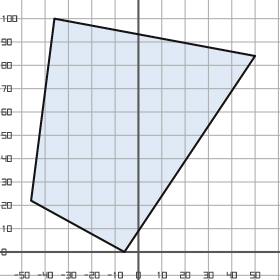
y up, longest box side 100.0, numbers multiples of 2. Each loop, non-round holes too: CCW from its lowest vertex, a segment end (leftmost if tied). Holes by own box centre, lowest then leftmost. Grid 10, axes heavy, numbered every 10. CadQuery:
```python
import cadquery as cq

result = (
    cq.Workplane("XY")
    .moveTo(-6.0, 0.0)
    .lineTo(50.0, 84.0)
    .lineTo(-36.0, 100.0)
    .lineTo(-46.0, 22.0)
    .close()
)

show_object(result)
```